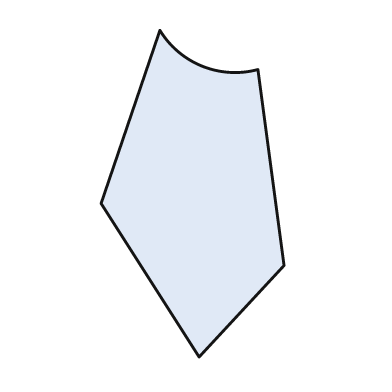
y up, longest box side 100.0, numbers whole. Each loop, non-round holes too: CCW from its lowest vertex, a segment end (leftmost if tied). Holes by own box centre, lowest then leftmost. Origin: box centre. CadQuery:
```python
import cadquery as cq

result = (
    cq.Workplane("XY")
    .moveTo(2.0, -50.0)
    .lineTo(28.0, -22.0)
    .lineTo(20.0, 38.0)
    .threePointArc((3.0, 39.0), (-10.0, 50.0))
    .lineTo(-28.0, -3.0)
    .close()
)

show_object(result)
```